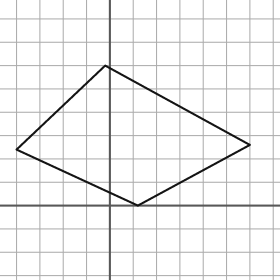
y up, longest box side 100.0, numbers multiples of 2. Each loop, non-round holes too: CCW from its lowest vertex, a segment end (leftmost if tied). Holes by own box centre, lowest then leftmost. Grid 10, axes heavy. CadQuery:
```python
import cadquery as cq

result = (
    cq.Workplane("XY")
    .moveTo(12.0, 0.0)
    .lineTo(60.0, 26.0)
    .lineTo(-2.0, 60.0)
    .lineTo(-40.0, 24.0)
    .close()
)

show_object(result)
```